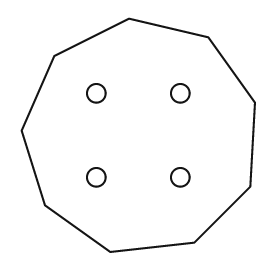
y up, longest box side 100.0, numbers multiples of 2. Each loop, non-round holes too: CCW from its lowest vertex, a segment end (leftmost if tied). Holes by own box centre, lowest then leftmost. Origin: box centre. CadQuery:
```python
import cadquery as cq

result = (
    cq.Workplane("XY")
    .moveTo(-12.0, -50.0)
    .lineTo(24.0, -46.0)
    .lineTo(48.0, -22.0)
    .lineTo(50.0, 14.0)
    .lineTo(30.0, 42.0)
    .lineTo(-4.0, 50.0)
    .lineTo(-36.0, 34.0)
    .lineTo(-50.0, 2.0)
    .lineTo(-40.0, -30.0)
    .close()
    .moveTo(-18.0, -18.0)
    .circle(4.0)
    .moveTo(18.0, -18.0)
    .circle(4.0)
    .moveTo(-18.0, 18.0)
    .circle(4.0)
    .moveTo(18.0, 18.0)
    .circle(4.0)
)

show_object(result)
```